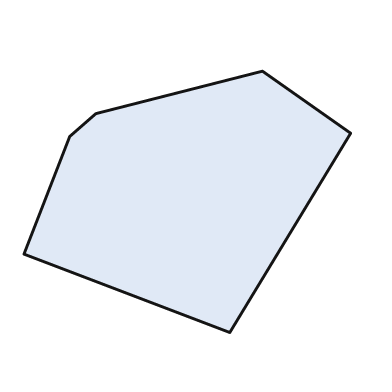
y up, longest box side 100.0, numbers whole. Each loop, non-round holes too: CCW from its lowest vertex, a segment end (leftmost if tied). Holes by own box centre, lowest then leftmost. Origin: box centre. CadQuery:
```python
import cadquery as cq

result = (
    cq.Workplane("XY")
    .moveTo(13.0, -40.0)
    .lineTo(50.0, 21.0)
    .lineTo(23.0, 40.0)
    .lineTo(-28.0, 27.0)
    .lineTo(-36.0, 20.0)
    .lineTo(-50.0, -16.0)
    .close()
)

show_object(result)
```